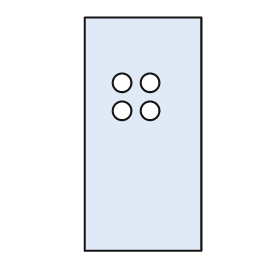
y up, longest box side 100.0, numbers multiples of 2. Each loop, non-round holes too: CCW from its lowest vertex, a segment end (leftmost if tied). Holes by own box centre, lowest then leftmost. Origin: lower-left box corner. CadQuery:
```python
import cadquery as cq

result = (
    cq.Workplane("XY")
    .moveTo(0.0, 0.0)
    .lineTo(50.0, 0.0)
    .lineTo(50.0, 100.0)
    .lineTo(0.0, 100.0)
    .close()
    .moveTo(16.0, 60.0)
    .circle(4.0)
    .moveTo(28.0, 60.0)
    .circle(4.0)
    .moveTo(16.0, 72.0)
    .circle(4.0)
    .moveTo(28.0, 72.0)
    .circle(4.0)
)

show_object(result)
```